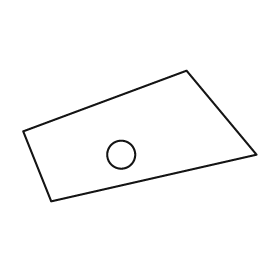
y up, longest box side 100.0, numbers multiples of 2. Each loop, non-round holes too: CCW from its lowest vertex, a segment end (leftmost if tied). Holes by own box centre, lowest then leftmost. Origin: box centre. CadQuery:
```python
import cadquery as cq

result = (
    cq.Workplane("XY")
    .moveTo(-38.0, -28.0)
    .lineTo(50.0, -8.0)
    .lineTo(20.0, 28.0)
    .lineTo(-50.0, 2.0)
    .close()
    .moveTo(-8.0, -8.0)
    .circle(6.0)
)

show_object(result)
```